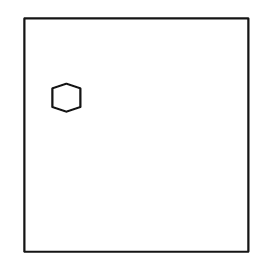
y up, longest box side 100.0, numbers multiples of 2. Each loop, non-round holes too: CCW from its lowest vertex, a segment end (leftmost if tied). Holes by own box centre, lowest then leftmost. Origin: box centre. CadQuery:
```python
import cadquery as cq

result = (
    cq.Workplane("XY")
    .moveTo(-48.0, -50.0)
    .lineTo(48.0, -50.0)
    .lineTo(48.0, 50.0)
    .lineTo(-48.0, 50.0)
    .close()
    .moveTo(-30.0, 10.0)
    .lineTo(-24.0, 12.0)
    .lineTo(-24.0, 20.0)
    .lineTo(-30.0, 22.0)
    .lineTo(-36.0, 20.0)
    .lineTo(-36.0, 12.0)
    .close()
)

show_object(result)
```